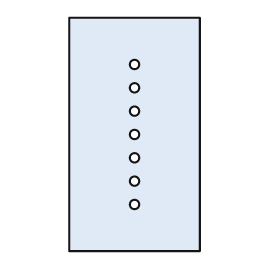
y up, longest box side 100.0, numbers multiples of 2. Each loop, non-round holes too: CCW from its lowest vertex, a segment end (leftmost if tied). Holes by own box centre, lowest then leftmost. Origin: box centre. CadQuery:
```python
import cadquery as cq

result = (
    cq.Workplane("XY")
    .moveTo(-28.0, -50.0)
    .lineTo(28.0, -50.0)
    .lineTo(28.0, 50.0)
    .lineTo(-28.0, 50.0)
    .close()
    .moveTo(0.0, -30.0)
    .circle(2.0)
    .moveTo(0.0, -20.0)
    .circle(2.0)
    .moveTo(0.0, -10.0)
    .circle(2.0)
    .moveTo(0.0, 0.0)
    .circle(2.0)
    .moveTo(0.0, 10.0)
    .circle(2.0)
    .moveTo(0.0, 20.0)
    .circle(2.0)
    .moveTo(0.0, 30.0)
    .circle(2.0)
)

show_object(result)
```